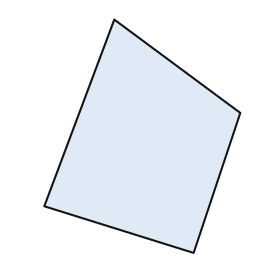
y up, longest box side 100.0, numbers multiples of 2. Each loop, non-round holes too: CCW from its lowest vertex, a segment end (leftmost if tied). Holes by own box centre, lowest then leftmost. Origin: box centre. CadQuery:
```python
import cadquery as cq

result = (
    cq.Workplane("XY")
    .moveTo(22.0, -50.0)
    .lineTo(42.0, 10.0)
    .lineTo(-12.0, 50.0)
    .lineTo(-42.0, -30.0)
    .close()
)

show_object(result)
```